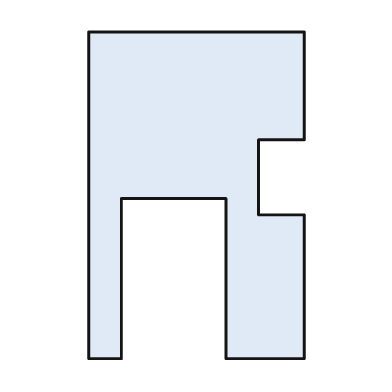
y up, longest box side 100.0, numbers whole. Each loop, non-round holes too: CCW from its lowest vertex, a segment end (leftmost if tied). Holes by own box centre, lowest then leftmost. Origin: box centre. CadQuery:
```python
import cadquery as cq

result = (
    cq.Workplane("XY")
    .moveTo(-33.0, -50.0)
    .lineTo(-23.0, -50.0)
    .lineTo(-23.0, -1.0)
    .lineTo(9.0, -1.0)
    .lineTo(9.0, -50.0)
    .lineTo(33.0, -50.0)
    .lineTo(33.0, -6.0)
    .lineTo(19.0, -6.0)
    .lineTo(19.0, 17.0)
    .lineTo(33.0, 17.0)
    .lineTo(33.0, 50.0)
    .lineTo(-33.0, 50.0)
    .close()
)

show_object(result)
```